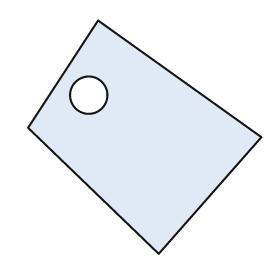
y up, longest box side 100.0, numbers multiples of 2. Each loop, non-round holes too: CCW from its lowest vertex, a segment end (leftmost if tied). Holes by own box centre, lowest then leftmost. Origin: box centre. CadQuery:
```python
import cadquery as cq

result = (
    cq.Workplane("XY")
    .moveTo(6.0, -50.0)
    .lineTo(50.0, 0.0)
    .lineTo(-20.0, 50.0)
    .lineTo(-50.0, 4.0)
    .close()
    .moveTo(-24.0, 18.0)
    .circle(8.0)
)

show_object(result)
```